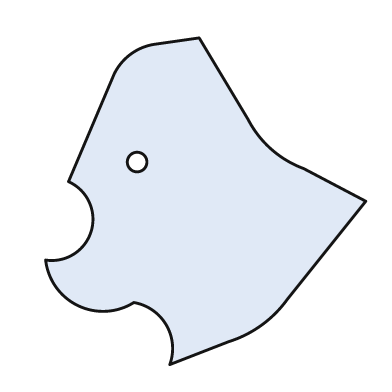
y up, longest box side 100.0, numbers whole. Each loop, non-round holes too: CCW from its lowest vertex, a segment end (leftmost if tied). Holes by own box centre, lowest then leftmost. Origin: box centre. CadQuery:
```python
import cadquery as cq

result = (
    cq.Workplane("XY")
    .moveTo(-11.0, -50.0)
    .lineTo(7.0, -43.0)
    .threePointArc((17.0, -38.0), (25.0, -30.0))
    .lineTo(49.0, 0.0)
    .lineTo(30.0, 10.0)
    .threePointArc((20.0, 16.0), (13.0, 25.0))
    .lineTo(-2.0, 50.0)
    .lineTo(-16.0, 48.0)
    .threePointArc((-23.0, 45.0), (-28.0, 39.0))
    .lineTo(-42.0, 6.0)
    .threePointArc((-35.0, -9.0), (-49.0, -18.0))
    .threePointArc((-39.0, -32.0), (-22.0, -31.0))
    .threePointArc((-12.0, -38.0), (-11.0, -50.0))
    .close()
    .moveTo(-21.0, 12.0)
    .circle(3.0)
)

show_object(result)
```